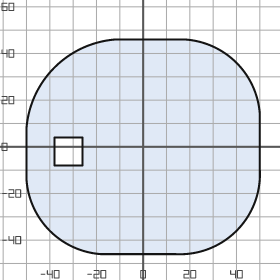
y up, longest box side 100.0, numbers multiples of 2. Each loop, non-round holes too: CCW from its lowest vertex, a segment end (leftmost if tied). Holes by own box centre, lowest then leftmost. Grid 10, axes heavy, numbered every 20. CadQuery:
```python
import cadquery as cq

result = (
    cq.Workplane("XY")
    .moveTo(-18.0, -46.0)
    .lineTo(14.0, -46.0)
    .threePointArc((40.0, -36.0), (50.0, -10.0))
    .lineTo(50.0, 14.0)
    .threePointArc((40.0, 36.0), (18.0, 46.0))
    .lineTo(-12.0, 46.0)
    .threePointArc((-38.0, 34.0), (-50.0, 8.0))
    .lineTo(-50.0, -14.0)
    .threePointArc((-40.0, -36.0), (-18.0, -46.0))
    .close()
    .moveTo(-38.0, -8.0)
    .lineTo(-26.0, -8.0)
    .lineTo(-26.0, 4.0)
    .lineTo(-38.0, 4.0)
    .close()
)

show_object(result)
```